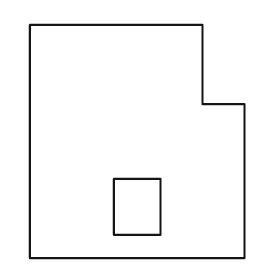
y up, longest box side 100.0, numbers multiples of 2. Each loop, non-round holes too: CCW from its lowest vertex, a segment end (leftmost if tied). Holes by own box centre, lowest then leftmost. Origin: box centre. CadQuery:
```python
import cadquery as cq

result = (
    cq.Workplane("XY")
    .moveTo(-46.0, -50.0)
    .lineTo(46.0, -50.0)
    .lineTo(46.0, 16.0)
    .lineTo(28.0, 16.0)
    .lineTo(28.0, 50.0)
    .lineTo(-46.0, 50.0)
    .close()
    .moveTo(-10.0, -40.0)
    .lineTo(10.0, -40.0)
    .lineTo(10.0, -16.0)
    .lineTo(-10.0, -16.0)
    .close()
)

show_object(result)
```